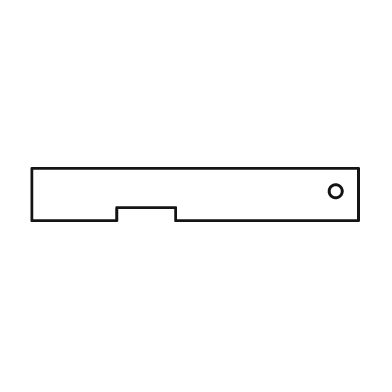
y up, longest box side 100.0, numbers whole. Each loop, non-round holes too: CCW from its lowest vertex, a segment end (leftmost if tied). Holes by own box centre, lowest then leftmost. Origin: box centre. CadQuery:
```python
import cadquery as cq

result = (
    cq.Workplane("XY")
    .moveTo(-50.0, -8.0)
    .lineTo(-24.0, -8.0)
    .lineTo(-24.0, -4.0)
    .lineTo(-6.0, -4.0)
    .lineTo(-6.0, -8.0)
    .lineTo(50.0, -8.0)
    .lineTo(50.0, 8.0)
    .lineTo(-50.0, 8.0)
    .close()
    .moveTo(43.0, 1.0)
    .circle(2.0)
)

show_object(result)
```